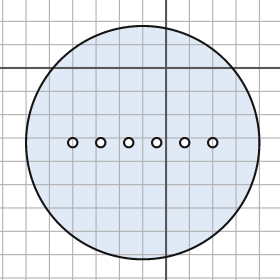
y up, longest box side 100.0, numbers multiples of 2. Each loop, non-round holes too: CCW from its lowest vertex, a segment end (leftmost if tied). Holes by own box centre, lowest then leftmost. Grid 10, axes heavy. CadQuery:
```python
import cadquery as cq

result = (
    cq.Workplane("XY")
    .moveTo(-10.0, -32.0)
    .circle(50.0)
    .moveTo(-40.0, -32.0)
    .circle(2.0)
    .moveTo(-28.0, -32.0)
    .circle(2.0)
    .moveTo(-16.0, -32.0)
    .circle(2.0)
    .moveTo(-4.0, -32.0)
    .circle(2.0)
    .moveTo(8.0, -32.0)
    .circle(2.0)
    .moveTo(20.0, -32.0)
    .circle(2.0)
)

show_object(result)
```